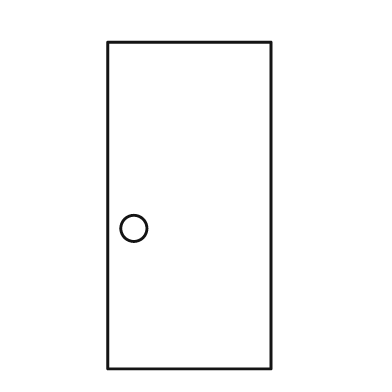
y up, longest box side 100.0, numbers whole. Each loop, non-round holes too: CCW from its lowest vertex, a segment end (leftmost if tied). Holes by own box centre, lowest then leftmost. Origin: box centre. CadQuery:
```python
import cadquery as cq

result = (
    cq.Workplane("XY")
    .moveTo(-25.0, -50.0)
    .lineTo(25.0, -50.0)
    .lineTo(25.0, 50.0)
    .lineTo(-25.0, 50.0)
    .close()
    .moveTo(-17.0, -7.0)
    .circle(4.0)
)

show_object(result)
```